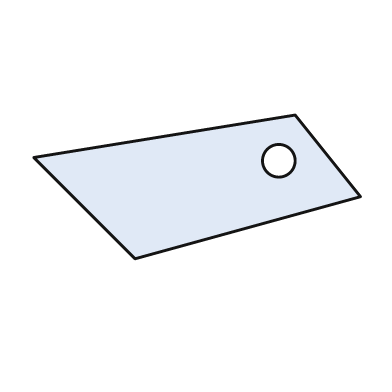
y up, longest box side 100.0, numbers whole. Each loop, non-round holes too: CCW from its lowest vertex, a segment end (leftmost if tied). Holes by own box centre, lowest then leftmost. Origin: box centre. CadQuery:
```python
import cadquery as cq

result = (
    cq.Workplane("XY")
    .moveTo(-19.0, -22.0)
    .lineTo(50.0, -3.0)
    .lineTo(30.0, 22.0)
    .lineTo(-50.0, 9.0)
    .close()
    .moveTo(25.0, 8.0)
    .circle(5.0)
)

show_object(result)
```